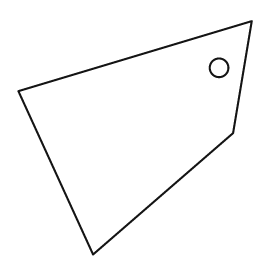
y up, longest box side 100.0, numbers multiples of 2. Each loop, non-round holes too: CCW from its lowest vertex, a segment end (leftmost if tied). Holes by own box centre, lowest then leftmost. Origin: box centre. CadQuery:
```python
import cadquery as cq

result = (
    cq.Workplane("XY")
    .moveTo(-18.0, -50.0)
    .lineTo(42.0, 2.0)
    .lineTo(50.0, 50.0)
    .lineTo(-50.0, 20.0)
    .close()
    .moveTo(36.0, 30.0)
    .circle(4.0)
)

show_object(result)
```